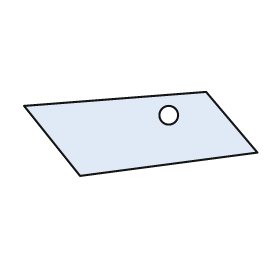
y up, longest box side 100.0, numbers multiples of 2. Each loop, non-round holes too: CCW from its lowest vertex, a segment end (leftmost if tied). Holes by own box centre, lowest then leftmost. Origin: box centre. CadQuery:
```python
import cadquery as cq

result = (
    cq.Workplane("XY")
    .moveTo(-26.0, -18.0)
    .lineTo(50.0, -8.0)
    .lineTo(28.0, 18.0)
    .lineTo(-50.0, 12.0)
    .close()
    .moveTo(12.0, 8.0)
    .circle(4.0)
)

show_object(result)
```